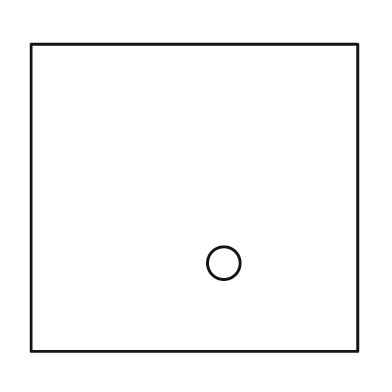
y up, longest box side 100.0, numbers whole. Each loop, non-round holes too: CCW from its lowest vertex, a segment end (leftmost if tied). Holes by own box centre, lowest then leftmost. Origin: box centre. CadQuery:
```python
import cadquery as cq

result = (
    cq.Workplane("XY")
    .moveTo(-50.0, -47.0)
    .lineTo(50.0, -47.0)
    .lineTo(50.0, 47.0)
    .lineTo(-50.0, 47.0)
    .close()
    .moveTo(9.0, -20.0)
    .circle(5.0)
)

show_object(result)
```